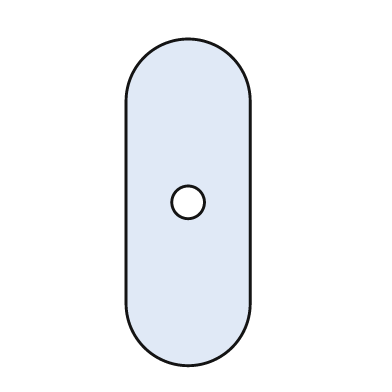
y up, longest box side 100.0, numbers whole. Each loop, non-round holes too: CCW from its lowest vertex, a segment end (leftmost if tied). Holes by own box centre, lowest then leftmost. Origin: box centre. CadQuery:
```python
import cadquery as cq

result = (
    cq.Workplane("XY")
    .moveTo(-19.0, -31.0)
    .threePointArc((0.0, -50.0), (19.0, -31.0))
    .lineTo(19.0, 31.0)
    .threePointArc((0.0, 50.0), (-19.0, 31.0))
    .close()
    .moveTo(0.0, 0.0)
    .circle(5.0)
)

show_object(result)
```